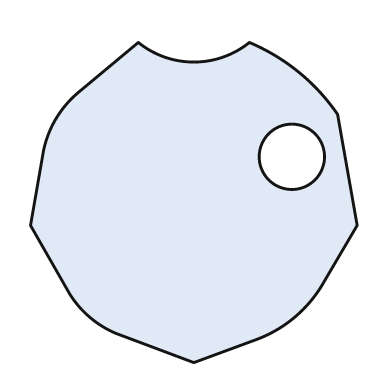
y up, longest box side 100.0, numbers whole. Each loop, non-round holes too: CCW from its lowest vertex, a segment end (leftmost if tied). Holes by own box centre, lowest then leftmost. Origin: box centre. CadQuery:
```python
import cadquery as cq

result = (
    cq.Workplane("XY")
    .moveTo(0.0, -49.0)
    .lineTo(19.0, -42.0)
    .threePointArc((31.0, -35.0), (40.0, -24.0))
    .lineTo(50.0, -7.0)
    .lineTo(44.0, 27.0)
    .threePointArc((32.0, 40.0), (17.0, 49.0))
    .threePointArc((0.0, 43.0), (-17.0, 49.0))
    .lineTo(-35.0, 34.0)
    .threePointArc((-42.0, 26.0), (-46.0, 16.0))
    .lineTo(-50.0, -7.0)
    .lineTo(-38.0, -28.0)
    .threePointArc((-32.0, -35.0), (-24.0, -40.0))
    .close()
    .moveTo(30.0, 14.0)
    .circle(10.0)
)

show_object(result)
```